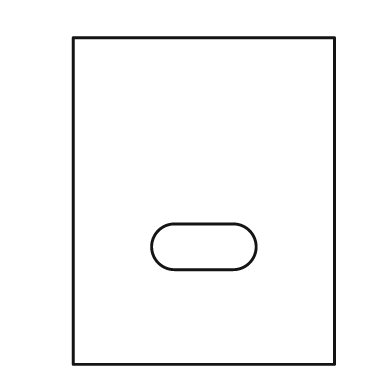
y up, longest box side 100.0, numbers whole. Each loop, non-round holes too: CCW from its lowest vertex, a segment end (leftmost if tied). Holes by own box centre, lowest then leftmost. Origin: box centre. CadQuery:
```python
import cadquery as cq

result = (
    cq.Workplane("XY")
    .moveTo(-40.0, -50.0)
    .lineTo(40.0, -50.0)
    .lineTo(40.0, 50.0)
    .lineTo(-40.0, 50.0)
    .close()
    .moveTo(-9.0, -21.0)
    .lineTo(9.0, -21.0)
    .threePointArc((16.0, -14.0), (9.0, -7.0))
    .lineTo(-9.0, -7.0)
    .threePointArc((-16.0, -14.0), (-9.0, -21.0))
    .close()
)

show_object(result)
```